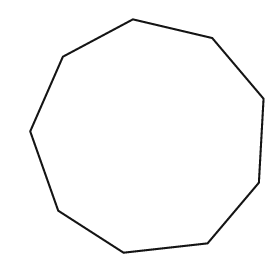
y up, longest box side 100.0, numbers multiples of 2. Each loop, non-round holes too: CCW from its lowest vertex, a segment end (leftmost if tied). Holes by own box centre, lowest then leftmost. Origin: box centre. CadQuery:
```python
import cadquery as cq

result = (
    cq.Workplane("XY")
    .moveTo(-10.0, -50.0)
    .lineTo(26.0, -46.0)
    .lineTo(48.0, -20.0)
    .lineTo(50.0, 16.0)
    .lineTo(28.0, 42.0)
    .lineTo(-6.0, 50.0)
    .lineTo(-36.0, 34.0)
    .lineTo(-50.0, 2.0)
    .lineTo(-38.0, -32.0)
    .close()
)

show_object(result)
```